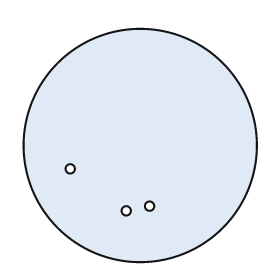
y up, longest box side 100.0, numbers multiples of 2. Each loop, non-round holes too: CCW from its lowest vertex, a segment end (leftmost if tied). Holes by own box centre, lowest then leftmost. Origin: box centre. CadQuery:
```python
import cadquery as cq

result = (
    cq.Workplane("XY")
    .moveTo(0.0, 0.0)
    .circle(50.0)
    .moveTo(-6.0, -28.0)
    .circle(2.0)
    .moveTo(4.0, -26.0)
    .circle(2.0)
    .moveTo(-30.0, -10.0)
    .circle(2.0)
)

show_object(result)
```